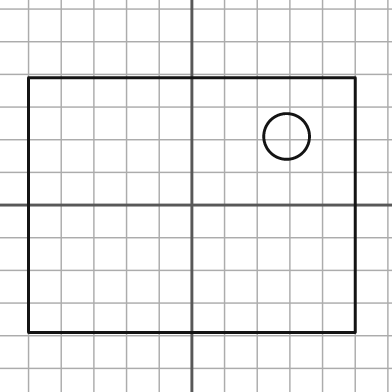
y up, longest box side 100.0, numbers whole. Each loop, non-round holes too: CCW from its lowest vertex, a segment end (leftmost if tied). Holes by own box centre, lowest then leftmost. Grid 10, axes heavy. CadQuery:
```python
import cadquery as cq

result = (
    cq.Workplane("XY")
    .moveTo(-50.0, -39.0)
    .lineTo(50.0, -39.0)
    .lineTo(50.0, 39.0)
    .lineTo(-50.0, 39.0)
    .close()
    .moveTo(29.0, 21.0)
    .circle(7.0)
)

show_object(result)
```